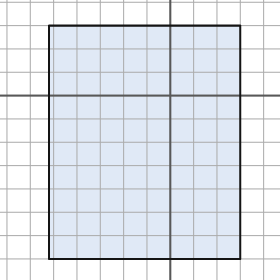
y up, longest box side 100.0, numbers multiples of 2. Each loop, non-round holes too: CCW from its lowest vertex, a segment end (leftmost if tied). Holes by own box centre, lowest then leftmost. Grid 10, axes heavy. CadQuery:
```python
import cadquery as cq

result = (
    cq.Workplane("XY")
    .moveTo(-52.0, -70.0)
    .lineTo(30.0, -70.0)
    .lineTo(30.0, 30.0)
    .lineTo(-52.0, 30.0)
    .close()
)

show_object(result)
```